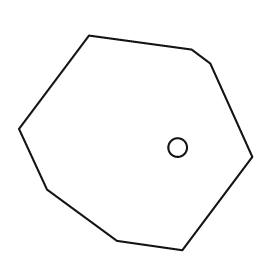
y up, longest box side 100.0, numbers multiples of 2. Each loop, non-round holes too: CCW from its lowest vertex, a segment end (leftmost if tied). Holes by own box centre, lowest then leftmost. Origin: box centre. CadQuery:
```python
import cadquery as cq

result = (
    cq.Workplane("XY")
    .moveTo(20.0, -46.0)
    .lineTo(50.0, -6.0)
    .lineTo(32.0, 34.0)
    .lineTo(24.0, 40.0)
    .lineTo(-20.0, 46.0)
    .lineTo(-50.0, 6.0)
    .lineTo(-38.0, -20.0)
    .lineTo(-8.0, -42.0)
    .close()
    .moveTo(18.0, -2.0)
    .circle(4.0)
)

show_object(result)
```